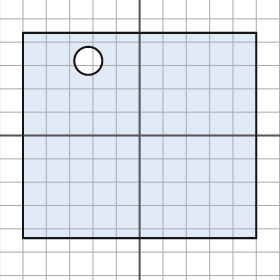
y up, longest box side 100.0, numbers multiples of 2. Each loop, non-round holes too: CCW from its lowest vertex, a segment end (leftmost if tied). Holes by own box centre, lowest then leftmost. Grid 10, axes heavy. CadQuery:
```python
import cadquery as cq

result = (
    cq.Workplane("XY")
    .moveTo(-50.0, -44.0)
    .lineTo(50.0, -44.0)
    .lineTo(50.0, 44.0)
    .lineTo(-50.0, 44.0)
    .close()
    .moveTo(-22.0, 32.0)
    .circle(6.0)
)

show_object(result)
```